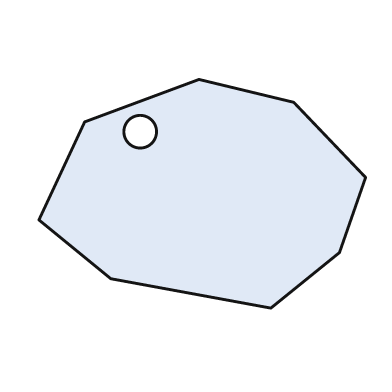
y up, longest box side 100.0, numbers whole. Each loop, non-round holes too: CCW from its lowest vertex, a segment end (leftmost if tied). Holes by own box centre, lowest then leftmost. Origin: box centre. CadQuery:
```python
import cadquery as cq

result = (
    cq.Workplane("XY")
    .moveTo(21.0, -35.0)
    .lineTo(42.0, -18.0)
    .lineTo(50.0, 5.0)
    .lineTo(28.0, 28.0)
    .lineTo(-1.0, 35.0)
    .lineTo(-36.0, 22.0)
    .lineTo(-50.0, -8.0)
    .lineTo(-28.0, -26.0)
    .close()
    .moveTo(-19.0, 19.0)
    .circle(5.0)
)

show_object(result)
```